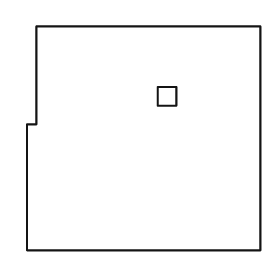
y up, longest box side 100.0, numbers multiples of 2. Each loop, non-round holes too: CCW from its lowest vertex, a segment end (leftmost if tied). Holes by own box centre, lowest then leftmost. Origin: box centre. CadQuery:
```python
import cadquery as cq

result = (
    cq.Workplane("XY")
    .moveTo(-50.0, -48.0)
    .lineTo(50.0, -48.0)
    .lineTo(50.0, 48.0)
    .lineTo(-46.0, 48.0)
    .lineTo(-46.0, 6.0)
    .lineTo(-50.0, 6.0)
    .close()
    .moveTo(6.0, 14.0)
    .lineTo(14.0, 14.0)
    .lineTo(14.0, 22.0)
    .lineTo(6.0, 22.0)
    .close()
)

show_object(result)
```